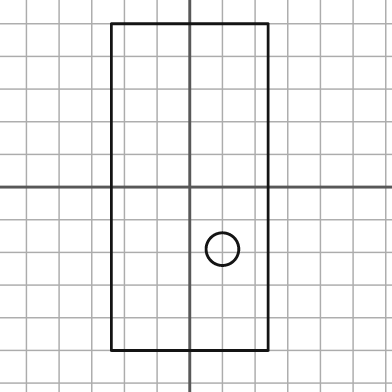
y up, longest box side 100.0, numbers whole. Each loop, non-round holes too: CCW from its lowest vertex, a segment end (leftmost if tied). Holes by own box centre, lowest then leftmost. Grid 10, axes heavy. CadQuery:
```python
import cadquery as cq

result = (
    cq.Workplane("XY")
    .moveTo(-24.0, -50.0)
    .lineTo(24.0, -50.0)
    .lineTo(24.0, 50.0)
    .lineTo(-24.0, 50.0)
    .close()
    .moveTo(10.0, -19.0)
    .circle(5.0)
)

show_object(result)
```